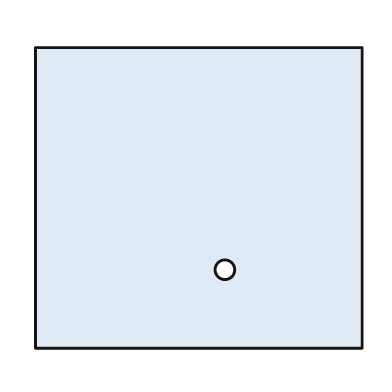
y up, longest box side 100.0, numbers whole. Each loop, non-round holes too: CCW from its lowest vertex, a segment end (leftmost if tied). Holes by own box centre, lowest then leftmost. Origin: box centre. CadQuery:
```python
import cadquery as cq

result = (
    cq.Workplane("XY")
    .moveTo(-50.0, -46.0)
    .lineTo(50.0, -46.0)
    .lineTo(50.0, 46.0)
    .lineTo(-50.0, 46.0)
    .close()
    .moveTo(8.0, -22.0)
    .circle(3.0)
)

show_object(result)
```